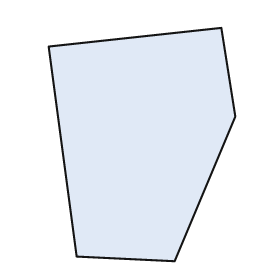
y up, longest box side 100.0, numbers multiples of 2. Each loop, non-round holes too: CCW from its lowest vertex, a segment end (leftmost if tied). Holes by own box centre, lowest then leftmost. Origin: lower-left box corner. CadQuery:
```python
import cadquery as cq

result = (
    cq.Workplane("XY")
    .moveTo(54.0, 0.0)
    .lineTo(80.0, 62.0)
    .lineTo(74.0, 100.0)
    .lineTo(0.0, 92.0)
    .lineTo(12.0, 2.0)
    .close()
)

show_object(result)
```